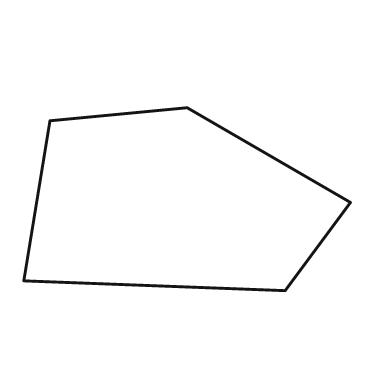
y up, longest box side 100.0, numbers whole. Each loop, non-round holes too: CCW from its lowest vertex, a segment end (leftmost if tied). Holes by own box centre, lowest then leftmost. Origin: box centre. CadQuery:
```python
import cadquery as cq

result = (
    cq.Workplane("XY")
    .moveTo(30.0, -28.0)
    .lineTo(50.0, -1.0)
    .lineTo(0.0, 28.0)
    .lineTo(-42.0, 24.0)
    .lineTo(-50.0, -25.0)
    .close()
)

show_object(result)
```